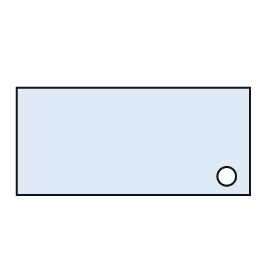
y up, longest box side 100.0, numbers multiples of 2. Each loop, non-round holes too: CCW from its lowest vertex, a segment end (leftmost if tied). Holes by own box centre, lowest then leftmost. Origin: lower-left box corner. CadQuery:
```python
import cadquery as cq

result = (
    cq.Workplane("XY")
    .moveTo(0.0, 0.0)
    .lineTo(100.0, 0.0)
    .lineTo(100.0, 46.0)
    .lineTo(0.0, 46.0)
    .close()
    .moveTo(90.0, 8.0)
    .circle(4.0)
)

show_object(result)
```